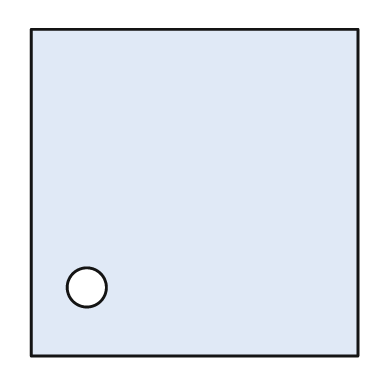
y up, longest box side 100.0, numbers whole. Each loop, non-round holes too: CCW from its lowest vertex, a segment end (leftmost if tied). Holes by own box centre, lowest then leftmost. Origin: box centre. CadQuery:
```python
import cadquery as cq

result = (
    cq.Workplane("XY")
    .moveTo(-50.0, -50.0)
    .lineTo(50.0, -50.0)
    .lineTo(50.0, 50.0)
    .lineTo(-50.0, 50.0)
    .close()
    .moveTo(-33.0, -29.0)
    .circle(6.0)
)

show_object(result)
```